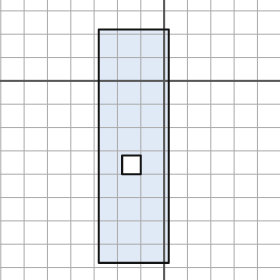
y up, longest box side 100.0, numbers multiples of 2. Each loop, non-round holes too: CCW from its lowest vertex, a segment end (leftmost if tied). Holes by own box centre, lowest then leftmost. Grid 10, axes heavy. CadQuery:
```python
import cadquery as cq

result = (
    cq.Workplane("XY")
    .moveTo(-28.0, -78.0)
    .lineTo(2.0, -78.0)
    .lineTo(2.0, 22.0)
    .lineTo(-28.0, 22.0)
    .close()
    .moveTo(-18.0, -40.0)
    .lineTo(-10.0, -40.0)
    .lineTo(-10.0, -32.0)
    .lineTo(-18.0, -32.0)
    .close()
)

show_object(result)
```